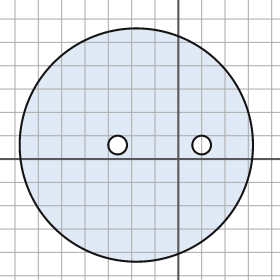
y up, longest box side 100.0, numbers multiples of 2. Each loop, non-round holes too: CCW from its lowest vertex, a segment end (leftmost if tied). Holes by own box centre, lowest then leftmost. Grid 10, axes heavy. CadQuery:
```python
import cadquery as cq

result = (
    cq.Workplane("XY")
    .moveTo(-18.0, 6.0)
    .circle(50.0)
    .moveTo(-26.0, 6.0)
    .circle(4.0)
    .moveTo(10.0, 6.0)
    .circle(4.0)
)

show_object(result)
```